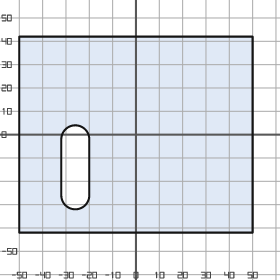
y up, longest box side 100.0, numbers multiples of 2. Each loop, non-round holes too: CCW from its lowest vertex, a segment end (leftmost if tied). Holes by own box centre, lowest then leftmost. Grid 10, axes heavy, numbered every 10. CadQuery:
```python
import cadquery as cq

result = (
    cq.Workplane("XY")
    .moveTo(-50.0, -42.0)
    .lineTo(50.0, -42.0)
    .lineTo(50.0, 42.0)
    .lineTo(-50.0, 42.0)
    .close()
    .moveTo(-32.0, -26.0)
    .threePointArc((-26.0, -32.0), (-20.0, -26.0))
    .lineTo(-20.0, -2.0)
    .threePointArc((-26.0, 4.0), (-32.0, -2.0))
    .close()
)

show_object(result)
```